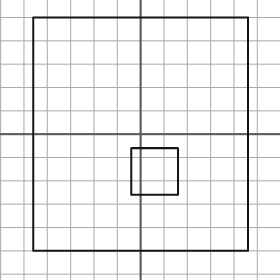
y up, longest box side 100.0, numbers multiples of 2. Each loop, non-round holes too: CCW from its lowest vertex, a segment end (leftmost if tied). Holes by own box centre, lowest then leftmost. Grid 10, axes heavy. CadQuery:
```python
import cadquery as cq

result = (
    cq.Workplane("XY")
    .moveTo(-46.0, -50.0)
    .lineTo(46.0, -50.0)
    .lineTo(46.0, 50.0)
    .lineTo(-46.0, 50.0)
    .close()
    .moveTo(-4.0, -26.0)
    .lineTo(16.0, -26.0)
    .lineTo(16.0, -6.0)
    .lineTo(-4.0, -6.0)
    .close()
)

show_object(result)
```